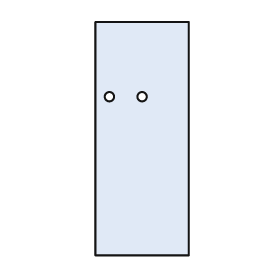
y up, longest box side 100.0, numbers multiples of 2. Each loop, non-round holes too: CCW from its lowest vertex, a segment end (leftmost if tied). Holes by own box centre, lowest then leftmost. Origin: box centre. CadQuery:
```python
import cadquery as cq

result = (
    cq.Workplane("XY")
    .moveTo(-20.0, -50.0)
    .lineTo(20.0, -50.0)
    .lineTo(20.0, 50.0)
    .lineTo(-20.0, 50.0)
    .close()
    .moveTo(-14.0, 18.0)
    .circle(2.0)
    .moveTo(0.0, 18.0)
    .circle(2.0)
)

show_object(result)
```